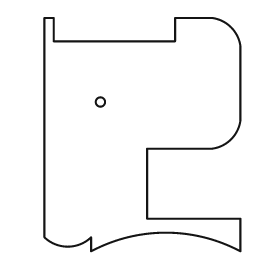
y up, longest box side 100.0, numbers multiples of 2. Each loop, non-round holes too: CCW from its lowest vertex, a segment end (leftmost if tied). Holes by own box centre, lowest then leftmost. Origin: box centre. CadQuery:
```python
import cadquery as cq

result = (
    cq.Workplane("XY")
    .moveTo(-22.0, -50.0)
    .threePointArc((10.0, -42.0), (42.0, -50.0))
    .lineTo(42.0, -36.0)
    .lineTo(2.0, -36.0)
    .lineTo(2.0, -6.0)
    .lineTo(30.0, -6.0)
    .threePointArc((38.0, -2.0), (42.0, 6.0))
    .lineTo(42.0, 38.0)
    .threePointArc((38.0, 46.0), (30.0, 50.0))
    .lineTo(14.0, 50.0)
    .lineTo(14.0, 40.0)
    .lineTo(-38.0, 40.0)
    .lineTo(-38.0, 50.0)
    .lineTo(-42.0, 50.0)
    .lineTo(-42.0, -44.0)
    .threePointArc((-32.0, -48.0), (-22.0, -44.0))
    .close()
    .moveTo(-18.0, 14.0)
    .circle(2.0)
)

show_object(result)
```